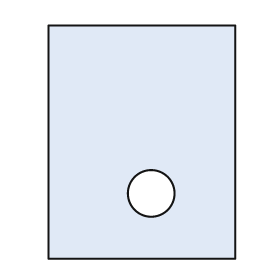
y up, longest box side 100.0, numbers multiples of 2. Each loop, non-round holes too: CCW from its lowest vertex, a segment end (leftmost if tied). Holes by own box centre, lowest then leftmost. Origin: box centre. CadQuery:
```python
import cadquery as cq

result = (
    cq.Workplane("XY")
    .moveTo(-40.0, -50.0)
    .lineTo(40.0, -50.0)
    .lineTo(40.0, 50.0)
    .lineTo(-40.0, 50.0)
    .close()
    .moveTo(4.0, -22.0)
    .circle(10.0)
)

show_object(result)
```